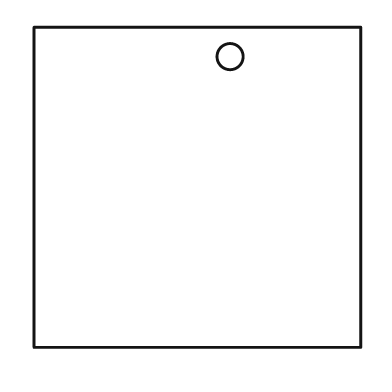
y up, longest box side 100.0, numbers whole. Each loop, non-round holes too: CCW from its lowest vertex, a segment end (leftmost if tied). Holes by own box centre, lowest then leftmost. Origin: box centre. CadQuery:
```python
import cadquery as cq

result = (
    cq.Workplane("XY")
    .moveTo(-50.0, -49.0)
    .lineTo(50.0, -49.0)
    .lineTo(50.0, 49.0)
    .lineTo(-50.0, 49.0)
    .close()
    .moveTo(10.0, 40.0)
    .circle(4.0)
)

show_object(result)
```